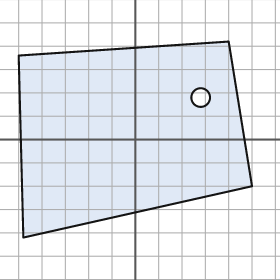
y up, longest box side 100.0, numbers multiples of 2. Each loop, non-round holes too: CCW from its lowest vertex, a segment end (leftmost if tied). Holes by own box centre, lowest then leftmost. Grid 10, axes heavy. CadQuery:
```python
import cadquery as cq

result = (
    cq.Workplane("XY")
    .moveTo(-48.0, -42.0)
    .lineTo(50.0, -20.0)
    .lineTo(40.0, 42.0)
    .lineTo(-50.0, 36.0)
    .close()
    .moveTo(28.0, 18.0)
    .circle(4.0)
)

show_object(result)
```